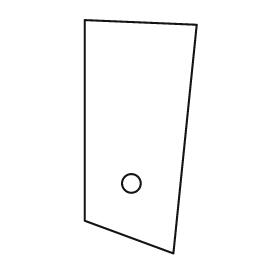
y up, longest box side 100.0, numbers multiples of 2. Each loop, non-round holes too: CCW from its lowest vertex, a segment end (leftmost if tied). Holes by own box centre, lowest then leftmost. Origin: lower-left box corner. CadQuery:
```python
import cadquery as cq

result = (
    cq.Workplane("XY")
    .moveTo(38.0, 0.0)
    .lineTo(48.0, 98.0)
    .lineTo(0.0, 100.0)
    .lineTo(0.0, 14.0)
    .close()
    .moveTo(20.0, 30.0)
    .circle(4.0)
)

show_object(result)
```